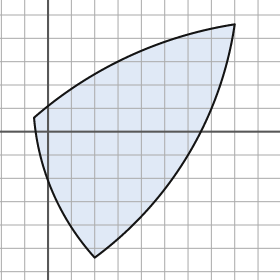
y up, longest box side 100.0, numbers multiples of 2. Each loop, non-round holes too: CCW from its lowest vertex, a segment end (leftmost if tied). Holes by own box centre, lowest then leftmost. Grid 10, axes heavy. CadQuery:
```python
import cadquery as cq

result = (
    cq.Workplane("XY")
    .moveTo(20.0, -54.0)
    .threePointArc((60.0, -10.0), (80.0, 46.0))
    .threePointArc((34.0, 32.0), (-6.0, 6.0))
    .threePointArc((2.0, -26.0), (20.0, -54.0))
    .close()
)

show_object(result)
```